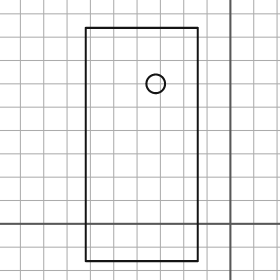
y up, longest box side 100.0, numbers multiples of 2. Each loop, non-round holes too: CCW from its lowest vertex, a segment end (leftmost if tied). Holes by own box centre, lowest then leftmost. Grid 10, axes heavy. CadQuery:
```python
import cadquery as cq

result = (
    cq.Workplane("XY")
    .moveTo(-62.0, -16.0)
    .lineTo(-14.0, -16.0)
    .lineTo(-14.0, 84.0)
    .lineTo(-62.0, 84.0)
    .close()
    .moveTo(-32.0, 60.0)
    .circle(4.0)
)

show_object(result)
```